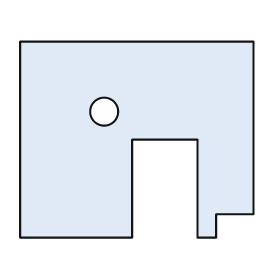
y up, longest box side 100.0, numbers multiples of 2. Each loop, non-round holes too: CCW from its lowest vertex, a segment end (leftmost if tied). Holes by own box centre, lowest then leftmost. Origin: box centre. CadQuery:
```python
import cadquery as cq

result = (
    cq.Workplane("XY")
    .moveTo(-50.0, -42.0)
    .lineTo(-2.0, -42.0)
    .lineTo(-2.0, 0.0)
    .lineTo(26.0, 0.0)
    .lineTo(26.0, -42.0)
    .lineTo(34.0, -42.0)
    .lineTo(34.0, -32.0)
    .lineTo(50.0, -32.0)
    .lineTo(50.0, 42.0)
    .lineTo(-50.0, 42.0)
    .close()
    .moveTo(-14.0, 12.0)
    .circle(6.0)
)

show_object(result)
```